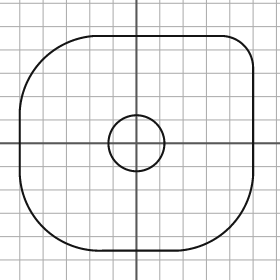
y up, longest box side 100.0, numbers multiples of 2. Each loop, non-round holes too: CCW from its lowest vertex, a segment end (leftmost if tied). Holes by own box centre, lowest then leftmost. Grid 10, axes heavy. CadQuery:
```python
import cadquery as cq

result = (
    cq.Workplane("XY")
    .moveTo(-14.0, -46.0)
    .lineTo(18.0, -46.0)
    .threePointArc((40.0, -36.0), (50.0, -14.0))
    .lineTo(50.0, 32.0)
    .threePointArc((46.0, 42.0), (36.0, 46.0))
    .lineTo(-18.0, 46.0)
    .threePointArc((-40.0, 36.0), (-50.0, 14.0))
    .lineTo(-50.0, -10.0)
    .threePointArc((-40.0, -36.0), (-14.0, -46.0))
    .close()
    .moveTo(0.0, 0.0)
    .circle(12.0)
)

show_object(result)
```